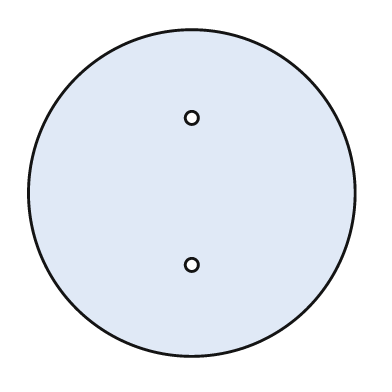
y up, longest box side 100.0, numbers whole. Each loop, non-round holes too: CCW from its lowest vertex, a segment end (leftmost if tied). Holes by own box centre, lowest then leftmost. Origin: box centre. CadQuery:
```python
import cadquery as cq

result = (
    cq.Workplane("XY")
    .moveTo(0.0, 0.0)
    .circle(50.0)
    .moveTo(0.0, -22.0)
    .circle(2.0)
    .moveTo(0.0, 23.0)
    .circle(2.0)
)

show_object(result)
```